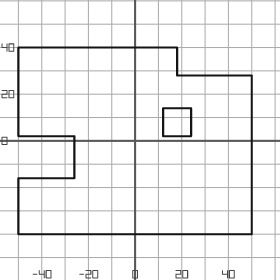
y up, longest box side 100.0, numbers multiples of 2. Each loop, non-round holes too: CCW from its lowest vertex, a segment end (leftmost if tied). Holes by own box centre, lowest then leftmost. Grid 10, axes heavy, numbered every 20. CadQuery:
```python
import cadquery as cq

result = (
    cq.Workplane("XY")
    .moveTo(-50.0, -40.0)
    .lineTo(50.0, -40.0)
    .lineTo(50.0, 28.0)
    .lineTo(18.0, 28.0)
    .lineTo(18.0, 40.0)
    .lineTo(-50.0, 40.0)
    .lineTo(-50.0, 2.0)
    .lineTo(-26.0, 2.0)
    .lineTo(-26.0, -16.0)
    .lineTo(-50.0, -16.0)
    .close()
    .moveTo(12.0, 2.0)
    .lineTo(24.0, 2.0)
    .lineTo(24.0, 14.0)
    .lineTo(12.0, 14.0)
    .close()
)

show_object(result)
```